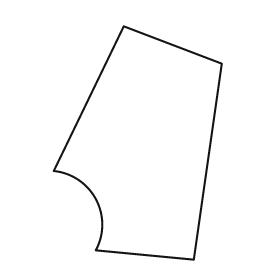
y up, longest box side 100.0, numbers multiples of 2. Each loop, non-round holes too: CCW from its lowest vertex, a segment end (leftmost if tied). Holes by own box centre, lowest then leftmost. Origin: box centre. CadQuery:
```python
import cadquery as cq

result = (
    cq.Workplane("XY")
    .moveTo(24.0, -50.0)
    .lineTo(36.0, 34.0)
    .lineTo(-6.0, 50.0)
    .lineTo(-36.0, -12.0)
    .threePointArc((-18.0, -24.0), (-18.0, -46.0))
    .close()
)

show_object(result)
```